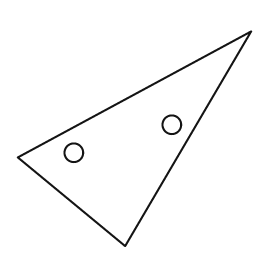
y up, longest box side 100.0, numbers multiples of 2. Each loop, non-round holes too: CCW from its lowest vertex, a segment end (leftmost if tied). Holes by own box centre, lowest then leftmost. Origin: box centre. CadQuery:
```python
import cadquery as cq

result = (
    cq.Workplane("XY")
    .moveTo(-4.0, -46.0)
    .lineTo(50.0, 46.0)
    .lineTo(-50.0, -8.0)
    .close()
    .moveTo(-26.0, -6.0)
    .circle(4.0)
    .moveTo(16.0, 6.0)
    .circle(4.0)
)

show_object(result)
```